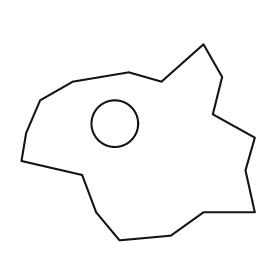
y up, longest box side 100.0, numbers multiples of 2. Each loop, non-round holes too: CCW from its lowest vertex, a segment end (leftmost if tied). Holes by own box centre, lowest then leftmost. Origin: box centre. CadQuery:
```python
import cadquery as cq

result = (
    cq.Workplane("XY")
    .moveTo(-8.0, -42.0)
    .lineTo(14.0, -40.0)
    .lineTo(28.0, -30.0)
    .lineTo(50.0, -30.0)
    .lineTo(46.0, -12.0)
    .lineTo(50.0, 2.0)
    .lineTo(32.0, 12.0)
    .lineTo(36.0, 28.0)
    .lineTo(28.0, 42.0)
    .lineTo(10.0, 26.0)
    .lineTo(-4.0, 30.0)
    .lineTo(-28.0, 26.0)
    .lineTo(-42.0, 18.0)
    .lineTo(-48.0, 4.0)
    .lineTo(-50.0, -8.0)
    .lineTo(-24.0, -14.0)
    .lineTo(-18.0, -30.0)
    .close()
    .moveTo(-10.0, 8.0)
    .circle(10.0)
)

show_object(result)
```